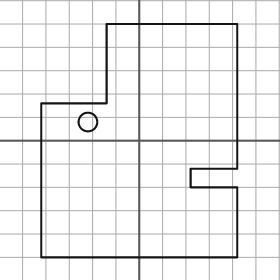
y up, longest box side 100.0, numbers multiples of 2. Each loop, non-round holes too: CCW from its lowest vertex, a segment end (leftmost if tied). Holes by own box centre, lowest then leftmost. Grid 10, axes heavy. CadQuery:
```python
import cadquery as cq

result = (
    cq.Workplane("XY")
    .moveTo(-42.0, -50.0)
    .lineTo(42.0, -50.0)
    .lineTo(42.0, -20.0)
    .lineTo(22.0, -20.0)
    .lineTo(22.0, -12.0)
    .lineTo(42.0, -12.0)
    .lineTo(42.0, 50.0)
    .lineTo(-14.0, 50.0)
    .lineTo(-14.0, 16.0)
    .lineTo(-42.0, 16.0)
    .close()
    .moveTo(-22.0, 8.0)
    .circle(4.0)
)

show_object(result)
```